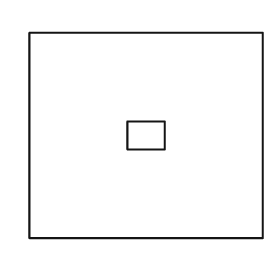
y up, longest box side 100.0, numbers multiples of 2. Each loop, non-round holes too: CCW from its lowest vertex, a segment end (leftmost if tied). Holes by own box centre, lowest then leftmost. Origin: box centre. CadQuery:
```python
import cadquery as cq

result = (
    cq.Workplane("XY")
    .moveTo(-50.0, -44.0)
    .lineTo(50.0, -44.0)
    .lineTo(50.0, 44.0)
    .lineTo(-50.0, 44.0)
    .close()
    .moveTo(-8.0, -6.0)
    .lineTo(8.0, -6.0)
    .lineTo(8.0, 6.0)
    .lineTo(-8.0, 6.0)
    .close()
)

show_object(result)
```